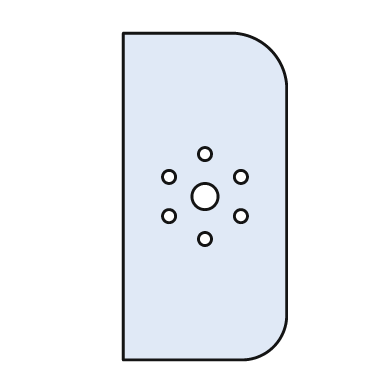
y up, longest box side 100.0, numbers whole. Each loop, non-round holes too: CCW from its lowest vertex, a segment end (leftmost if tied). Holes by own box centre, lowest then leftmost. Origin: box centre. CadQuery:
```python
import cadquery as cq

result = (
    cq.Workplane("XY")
    .moveTo(-25.0, -50.0)
    .lineTo(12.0, -50.0)
    .threePointArc((21.0, -46.0), (25.0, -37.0))
    .lineTo(25.0, 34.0)
    .threePointArc((20.0, 45.0), (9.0, 50.0))
    .lineTo(-25.0, 50.0)
    .close()
    .moveTo(0.0, -13.0)
    .circle(2.0)
    .moveTo(-11.0, -6.0)
    .circle(2.0)
    .moveTo(11.0, -6.0)
    .circle(2.0)
    .moveTo(0.0, 0.0)
    .circle(4.0)
    .moveTo(-11.0, 6.0)
    .circle(2.0)
    .moveTo(11.0, 6.0)
    .circle(2.0)
    .moveTo(0.0, 13.0)
    .circle(2.0)
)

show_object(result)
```